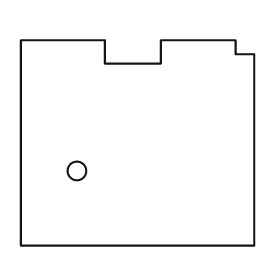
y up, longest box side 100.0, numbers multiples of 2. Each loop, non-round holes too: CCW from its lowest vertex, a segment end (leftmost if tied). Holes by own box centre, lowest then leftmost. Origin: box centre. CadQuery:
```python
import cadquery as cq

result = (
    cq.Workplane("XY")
    .moveTo(-50.0, -44.0)
    .lineTo(50.0, -44.0)
    .lineTo(50.0, 38.0)
    .lineTo(42.0, 38.0)
    .lineTo(42.0, 44.0)
    .lineTo(10.0, 44.0)
    .lineTo(10.0, 34.0)
    .lineTo(-14.0, 34.0)
    .lineTo(-14.0, 44.0)
    .lineTo(-50.0, 44.0)
    .close()
    .moveTo(-26.0, -12.0)
    .circle(4.0)
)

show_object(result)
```